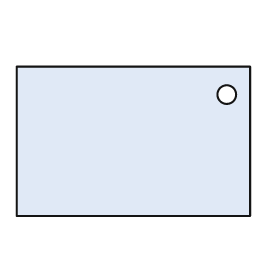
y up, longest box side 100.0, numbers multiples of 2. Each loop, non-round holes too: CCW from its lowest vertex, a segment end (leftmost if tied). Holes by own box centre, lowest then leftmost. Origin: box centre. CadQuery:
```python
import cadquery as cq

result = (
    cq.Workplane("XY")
    .moveTo(-50.0, -32.0)
    .lineTo(50.0, -32.0)
    .lineTo(50.0, 32.0)
    .lineTo(-50.0, 32.0)
    .close()
    .moveTo(40.0, 20.0)
    .circle(4.0)
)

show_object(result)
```